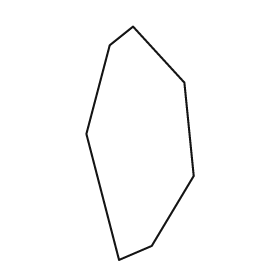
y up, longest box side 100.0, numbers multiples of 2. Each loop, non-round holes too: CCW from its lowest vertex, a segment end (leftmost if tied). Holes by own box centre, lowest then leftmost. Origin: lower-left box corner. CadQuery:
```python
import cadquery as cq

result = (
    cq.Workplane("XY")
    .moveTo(14.0, 0.0)
    .lineTo(28.0, 6.0)
    .lineTo(46.0, 36.0)
    .lineTo(42.0, 76.0)
    .lineTo(20.0, 100.0)
    .lineTo(10.0, 92.0)
    .lineTo(0.0, 54.0)
    .close()
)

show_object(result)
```